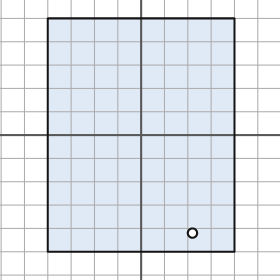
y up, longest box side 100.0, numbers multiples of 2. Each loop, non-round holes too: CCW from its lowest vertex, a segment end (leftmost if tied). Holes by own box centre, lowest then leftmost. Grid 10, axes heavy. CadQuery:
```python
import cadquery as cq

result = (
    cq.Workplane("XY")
    .moveTo(-40.0, -50.0)
    .lineTo(40.0, -50.0)
    .lineTo(40.0, 50.0)
    .lineTo(-40.0, 50.0)
    .close()
    .moveTo(22.0, -42.0)
    .circle(2.0)
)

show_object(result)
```